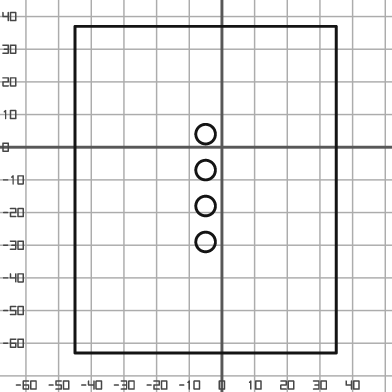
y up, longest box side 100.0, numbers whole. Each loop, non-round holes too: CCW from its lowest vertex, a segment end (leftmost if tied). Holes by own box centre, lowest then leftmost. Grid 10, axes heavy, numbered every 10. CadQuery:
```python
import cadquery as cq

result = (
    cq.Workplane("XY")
    .moveTo(-45.0, -63.0)
    .lineTo(35.0, -63.0)
    .lineTo(35.0, 37.0)
    .lineTo(-45.0, 37.0)
    .close()
    .moveTo(-5.0, -29.0)
    .circle(3.0)
    .moveTo(-5.0, -18.0)
    .circle(3.0)
    .moveTo(-5.0, -7.0)
    .circle(3.0)
    .moveTo(-5.0, 4.0)
    .circle(3.0)
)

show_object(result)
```